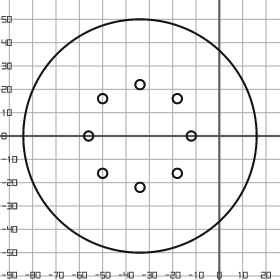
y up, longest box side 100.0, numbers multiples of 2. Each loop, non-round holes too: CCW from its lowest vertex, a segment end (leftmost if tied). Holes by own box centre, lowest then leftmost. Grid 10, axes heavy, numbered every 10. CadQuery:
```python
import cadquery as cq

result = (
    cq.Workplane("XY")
    .moveTo(-34.0, 0.0)
    .circle(50.0)
    .moveTo(-34.0, -22.0)
    .circle(2.0)
    .moveTo(-50.0, -16.0)
    .circle(2.0)
    .moveTo(-18.0, -16.0)
    .circle(2.0)
    .moveTo(-56.0, 0.0)
    .circle(2.0)
    .moveTo(-12.0, 0.0)
    .circle(2.0)
    .moveTo(-50.0, 16.0)
    .circle(2.0)
    .moveTo(-18.0, 16.0)
    .circle(2.0)
    .moveTo(-34.0, 22.0)
    .circle(2.0)
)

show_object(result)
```